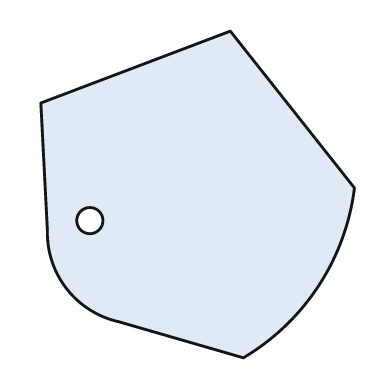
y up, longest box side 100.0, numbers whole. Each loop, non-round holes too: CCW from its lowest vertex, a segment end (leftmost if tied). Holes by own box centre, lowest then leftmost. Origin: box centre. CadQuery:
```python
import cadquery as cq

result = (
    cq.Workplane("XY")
    .moveTo(14.0, -50.0)
    .threePointArc((37.0, -28.0), (48.0, 2.0))
    .lineTo(10.0, 50.0)
    .lineTo(-48.0, 28.0)
    .lineTo(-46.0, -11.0)
    .threePointArc((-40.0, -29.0), (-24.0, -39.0))
    .close()
    .moveTo(-33.0, -8.0)
    .circle(4.0)
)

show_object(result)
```